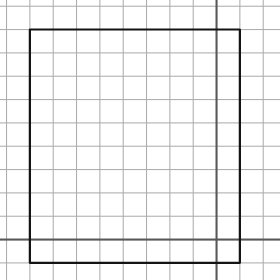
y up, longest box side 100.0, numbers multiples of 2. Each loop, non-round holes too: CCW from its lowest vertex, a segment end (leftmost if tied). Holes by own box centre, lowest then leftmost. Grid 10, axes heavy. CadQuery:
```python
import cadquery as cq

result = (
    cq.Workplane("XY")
    .moveTo(-80.0, -10.0)
    .lineTo(10.0, -10.0)
    .lineTo(10.0, 90.0)
    .lineTo(-80.0, 90.0)
    .close()
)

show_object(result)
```